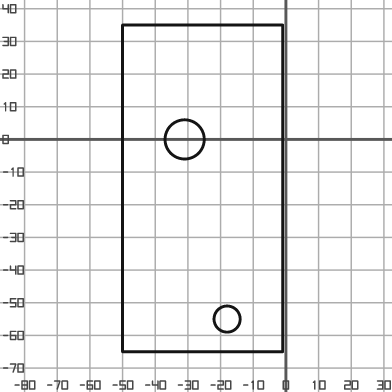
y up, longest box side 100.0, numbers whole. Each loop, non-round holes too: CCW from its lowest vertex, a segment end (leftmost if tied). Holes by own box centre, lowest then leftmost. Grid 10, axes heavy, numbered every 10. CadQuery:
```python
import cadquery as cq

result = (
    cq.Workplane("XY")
    .moveTo(-50.0, -65.0)
    .lineTo(-1.0, -65.0)
    .lineTo(-1.0, 35.0)
    .lineTo(-50.0, 35.0)
    .close()
    .moveTo(-18.0, -55.0)
    .circle(4.0)
    .moveTo(-31.0, 0.0)
    .circle(6.0)
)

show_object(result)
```